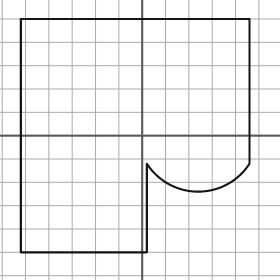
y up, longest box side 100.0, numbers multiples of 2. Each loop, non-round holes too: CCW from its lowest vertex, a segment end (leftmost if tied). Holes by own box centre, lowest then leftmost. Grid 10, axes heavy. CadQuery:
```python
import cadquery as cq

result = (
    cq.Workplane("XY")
    .moveTo(-52.0, -50.0)
    .lineTo(2.0, -50.0)
    .lineTo(2.0, -12.0)
    .threePointArc((24.0, -24.0), (46.0, -12.0))
    .lineTo(46.0, 50.0)
    .lineTo(-52.0, 50.0)
    .close()
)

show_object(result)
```